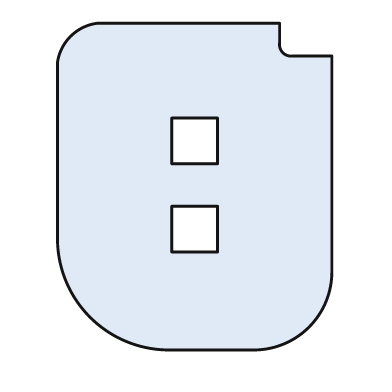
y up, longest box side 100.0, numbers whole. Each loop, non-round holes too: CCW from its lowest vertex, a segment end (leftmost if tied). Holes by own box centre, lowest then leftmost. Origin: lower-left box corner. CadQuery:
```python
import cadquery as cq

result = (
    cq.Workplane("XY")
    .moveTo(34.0, 0.0)
    .lineTo(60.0, 0.0)
    .threePointArc((77.0, 7.0), (84.0, 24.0))
    .lineTo(84.0, 90.0)
    .lineTo(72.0, 90.0)
    .threePointArc((69.0, 91.0), (68.0, 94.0))
    .lineTo(68.0, 100.0)
    .lineTo(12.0, 100.0)
    .threePointArc((4.0, 96.0), (0.0, 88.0))
    .lineTo(0.0, 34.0)
    .threePointArc((10.0, 10.0), (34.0, 0.0))
    .close()
    .moveTo(35.0, 30.0)
    .lineTo(49.0, 30.0)
    .lineTo(49.0, 44.0)
    .lineTo(35.0, 44.0)
    .close()
    .moveTo(35.0, 57.0)
    .lineTo(49.0, 57.0)
    .lineTo(49.0, 71.0)
    .lineTo(35.0, 71.0)
    .close()
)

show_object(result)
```